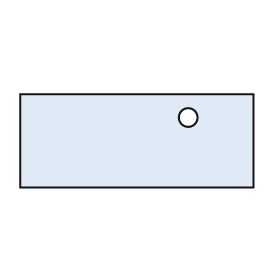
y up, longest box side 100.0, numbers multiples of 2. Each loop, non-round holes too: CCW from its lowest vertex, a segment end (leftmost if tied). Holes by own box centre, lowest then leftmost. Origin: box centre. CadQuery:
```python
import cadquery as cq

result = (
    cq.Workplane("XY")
    .moveTo(-50.0, -20.0)
    .lineTo(50.0, -20.0)
    .lineTo(50.0, 20.0)
    .lineTo(-50.0, 20.0)
    .close()
    .moveTo(22.0, 10.0)
    .circle(4.0)
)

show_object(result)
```